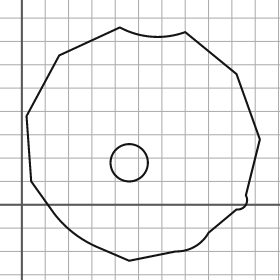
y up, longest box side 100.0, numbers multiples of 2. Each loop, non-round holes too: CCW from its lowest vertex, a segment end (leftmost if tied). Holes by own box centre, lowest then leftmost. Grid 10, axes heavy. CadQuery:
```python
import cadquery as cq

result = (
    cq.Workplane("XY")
    .moveTo(46.0, -24.0)
    .lineTo(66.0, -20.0)
    .threePointArc((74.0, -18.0), (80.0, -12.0))
    .lineTo(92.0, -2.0)
    .threePointArc((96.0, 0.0), (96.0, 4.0))
    .lineTo(102.0, 28.0)
    .lineTo(92.0, 56.0)
    .lineTo(70.0, 74.0)
    .threePointArc((56.0, 72.0), (42.0, 76.0))
    .lineTo(16.0, 64.0)
    .lineTo(2.0, 38.0)
    .lineTo(4.0, 10.0)
    .lineTo(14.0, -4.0)
    .threePointArc((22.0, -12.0), (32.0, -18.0))
    .close()
    .moveTo(46.0, 18.0)
    .circle(8.0)
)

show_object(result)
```